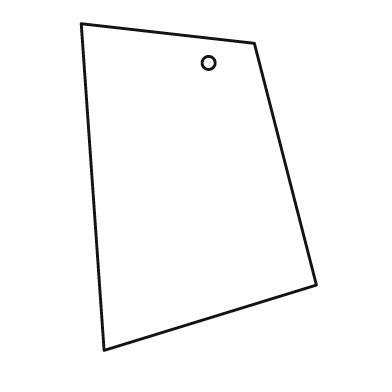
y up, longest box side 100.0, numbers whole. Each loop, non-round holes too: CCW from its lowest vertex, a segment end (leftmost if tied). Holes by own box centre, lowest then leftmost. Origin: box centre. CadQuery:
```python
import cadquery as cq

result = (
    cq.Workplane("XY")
    .moveTo(-29.0, -50.0)
    .lineTo(36.0, -30.0)
    .lineTo(17.0, 44.0)
    .lineTo(-36.0, 50.0)
    .close()
    .moveTo(3.0, 38.0)
    .circle(2.0)
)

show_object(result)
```